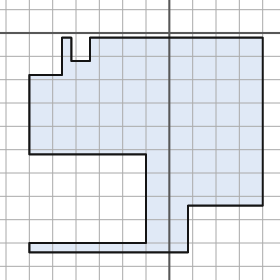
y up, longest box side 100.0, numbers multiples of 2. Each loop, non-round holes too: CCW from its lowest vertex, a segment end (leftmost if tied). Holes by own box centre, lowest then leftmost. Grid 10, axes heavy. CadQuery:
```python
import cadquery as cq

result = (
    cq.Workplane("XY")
    .moveTo(-60.0, -94.0)
    .lineTo(8.0, -94.0)
    .lineTo(8.0, -74.0)
    .lineTo(40.0, -74.0)
    .lineTo(40.0, -2.0)
    .lineTo(-34.0, -2.0)
    .lineTo(-34.0, -12.0)
    .lineTo(-42.0, -12.0)
    .lineTo(-42.0, -2.0)
    .lineTo(-46.0, -2.0)
    .lineTo(-46.0, -18.0)
    .lineTo(-60.0, -18.0)
    .lineTo(-60.0, -52.0)
    .lineTo(-10.0, -52.0)
    .lineTo(-10.0, -90.0)
    .lineTo(-60.0, -90.0)
    .close()
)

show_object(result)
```